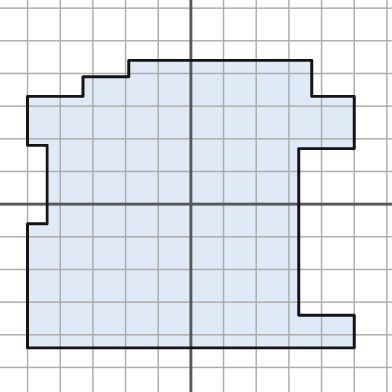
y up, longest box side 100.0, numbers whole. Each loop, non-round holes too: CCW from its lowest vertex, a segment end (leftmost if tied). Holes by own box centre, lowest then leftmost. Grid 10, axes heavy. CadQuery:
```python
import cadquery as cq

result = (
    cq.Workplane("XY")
    .moveTo(-50.0, -44.0)
    .lineTo(50.0, -44.0)
    .lineTo(50.0, -34.0)
    .lineTo(33.0, -34.0)
    .lineTo(33.0, 17.0)
    .lineTo(50.0, 17.0)
    .lineTo(50.0, 33.0)
    .lineTo(37.0, 33.0)
    .lineTo(37.0, 44.0)
    .lineTo(-19.0, 44.0)
    .lineTo(-19.0, 39.0)
    .lineTo(-33.0, 39.0)
    .lineTo(-33.0, 33.0)
    .lineTo(-50.0, 33.0)
    .lineTo(-50.0, 18.0)
    .lineTo(-44.0, 18.0)
    .lineTo(-44.0, -6.0)
    .lineTo(-50.0, -6.0)
    .close()
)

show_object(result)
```